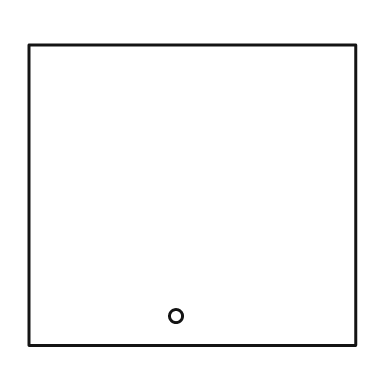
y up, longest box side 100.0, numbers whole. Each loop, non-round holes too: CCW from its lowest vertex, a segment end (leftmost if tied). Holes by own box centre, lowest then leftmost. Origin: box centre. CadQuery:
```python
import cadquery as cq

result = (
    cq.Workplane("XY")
    .moveTo(-50.0, -46.0)
    .lineTo(50.0, -46.0)
    .lineTo(50.0, 46.0)
    .lineTo(-50.0, 46.0)
    .close()
    .moveTo(-5.0, -37.0)
    .circle(2.0)
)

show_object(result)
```